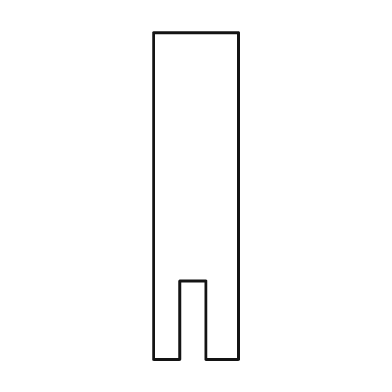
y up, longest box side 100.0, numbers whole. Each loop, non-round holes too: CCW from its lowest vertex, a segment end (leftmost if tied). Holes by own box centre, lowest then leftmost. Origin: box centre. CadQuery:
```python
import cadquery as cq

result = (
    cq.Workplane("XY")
    .moveTo(-13.0, -50.0)
    .lineTo(-5.0, -50.0)
    .lineTo(-5.0, -26.0)
    .lineTo(3.0, -26.0)
    .lineTo(3.0, -50.0)
    .lineTo(13.0, -50.0)
    .lineTo(13.0, 50.0)
    .lineTo(-13.0, 50.0)
    .close()
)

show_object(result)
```